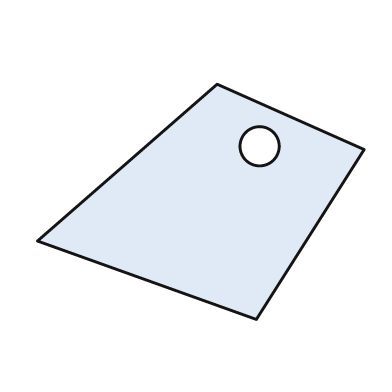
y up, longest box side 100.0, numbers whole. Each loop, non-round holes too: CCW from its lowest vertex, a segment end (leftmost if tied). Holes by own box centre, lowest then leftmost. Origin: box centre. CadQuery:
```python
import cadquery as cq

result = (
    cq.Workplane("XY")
    .moveTo(17.0, -36.0)
    .lineTo(50.0, 16.0)
    .lineTo(5.0, 36.0)
    .lineTo(-50.0, -12.0)
    .close()
    .moveTo(18.0, 17.0)
    .circle(6.0)
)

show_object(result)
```